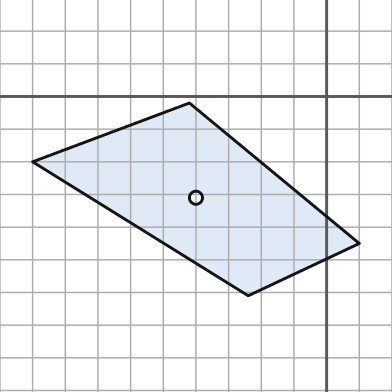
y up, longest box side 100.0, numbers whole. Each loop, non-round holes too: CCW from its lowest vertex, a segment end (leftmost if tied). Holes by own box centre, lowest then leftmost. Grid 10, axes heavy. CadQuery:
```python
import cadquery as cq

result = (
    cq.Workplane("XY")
    .moveTo(-24.0, -61.0)
    .lineTo(10.0, -45.0)
    .lineTo(-42.0, -2.0)
    .lineTo(-90.0, -20.0)
    .close()
    .moveTo(-40.0, -31.0)
    .circle(2.0)
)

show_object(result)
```